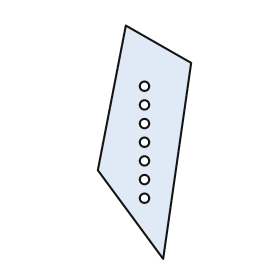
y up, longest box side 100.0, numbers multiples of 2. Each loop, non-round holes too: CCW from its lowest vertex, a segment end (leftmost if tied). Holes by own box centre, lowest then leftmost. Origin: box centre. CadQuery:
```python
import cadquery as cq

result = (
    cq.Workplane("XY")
    .moveTo(8.0, -50.0)
    .lineTo(20.0, 34.0)
    .lineTo(-8.0, 50.0)
    .lineTo(-20.0, -12.0)
    .close()
    .moveTo(0.0, -24.0)
    .circle(2.0)
    .moveTo(0.0, -16.0)
    .circle(2.0)
    .moveTo(0.0, -8.0)
    .circle(2.0)
    .moveTo(0.0, 0.0)
    .circle(2.0)
    .moveTo(0.0, 8.0)
    .circle(2.0)
    .moveTo(0.0, 16.0)
    .circle(2.0)
    .moveTo(0.0, 24.0)
    .circle(2.0)
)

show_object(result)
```